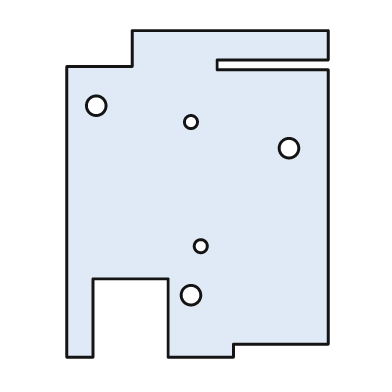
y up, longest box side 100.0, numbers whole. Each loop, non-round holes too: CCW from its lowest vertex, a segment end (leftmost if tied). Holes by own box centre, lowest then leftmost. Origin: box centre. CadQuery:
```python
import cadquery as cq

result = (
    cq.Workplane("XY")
    .moveTo(-40.0, -50.0)
    .lineTo(-32.0, -50.0)
    .lineTo(-32.0, -26.0)
    .lineTo(-9.0, -26.0)
    .lineTo(-9.0, -50.0)
    .lineTo(11.0, -50.0)
    .lineTo(11.0, -46.0)
    .lineTo(40.0, -46.0)
    .lineTo(40.0, 38.0)
    .lineTo(6.0, 38.0)
    .lineTo(6.0, 41.0)
    .lineTo(40.0, 41.0)
    .lineTo(40.0, 50.0)
    .lineTo(-20.0, 50.0)
    .lineTo(-20.0, 39.0)
    .lineTo(-40.0, 39.0)
    .close()
    .moveTo(-2.0, -31.0)
    .circle(3.0)
    .moveTo(1.0, -16.0)
    .circle(2.0)
    .moveTo(28.0, 14.0)
    .circle(3.0)
    .moveTo(-2.0, 22.0)
    .circle(2.0)
    .moveTo(-31.0, 27.0)
    .circle(3.0)
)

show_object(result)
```